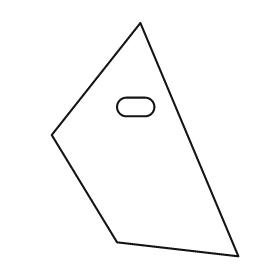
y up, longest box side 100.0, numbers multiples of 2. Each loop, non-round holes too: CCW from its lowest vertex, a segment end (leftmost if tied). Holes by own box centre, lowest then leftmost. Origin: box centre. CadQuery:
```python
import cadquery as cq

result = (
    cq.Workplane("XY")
    .moveTo(40.0, -50.0)
    .lineTo(-2.0, 50.0)
    .lineTo(-40.0, 2.0)
    .lineTo(-12.0, -44.0)
    .close()
    .moveTo(-8.0, 10.0)
    .lineTo(0.0, 10.0)
    .threePointArc((4.0, 14.0), (0.0, 18.0))
    .lineTo(-8.0, 18.0)
    .threePointArc((-12.0, 14.0), (-8.0, 10.0))
    .close()
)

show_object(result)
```